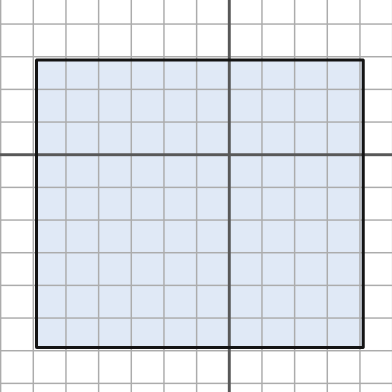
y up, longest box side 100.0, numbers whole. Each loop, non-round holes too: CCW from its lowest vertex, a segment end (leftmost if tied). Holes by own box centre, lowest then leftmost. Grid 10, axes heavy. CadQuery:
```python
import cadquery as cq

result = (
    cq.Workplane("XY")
    .moveTo(-59.0, -59.0)
    .lineTo(41.0, -59.0)
    .lineTo(41.0, 29.0)
    .lineTo(-59.0, 29.0)
    .close()
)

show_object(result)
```